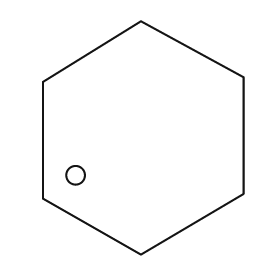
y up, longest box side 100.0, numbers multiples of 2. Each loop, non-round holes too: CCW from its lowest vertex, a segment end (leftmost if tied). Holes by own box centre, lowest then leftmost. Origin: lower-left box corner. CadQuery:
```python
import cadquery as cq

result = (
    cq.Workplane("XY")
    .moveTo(42.0, 0.0)
    .lineTo(86.0, 26.0)
    .lineTo(86.0, 76.0)
    .lineTo(42.0, 100.0)
    .lineTo(0.0, 74.0)
    .lineTo(0.0, 24.0)
    .close()
    .moveTo(14.0, 34.0)
    .circle(4.0)
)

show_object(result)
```